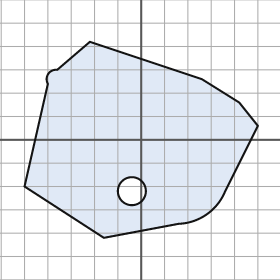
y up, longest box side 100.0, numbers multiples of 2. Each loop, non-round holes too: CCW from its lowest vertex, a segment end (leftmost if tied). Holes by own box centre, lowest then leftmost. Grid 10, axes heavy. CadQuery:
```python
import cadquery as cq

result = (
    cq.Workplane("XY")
    .moveTo(-16.0, -42.0)
    .lineTo(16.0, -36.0)
    .threePointArc((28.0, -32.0), (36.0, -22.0))
    .lineTo(50.0, 6.0)
    .lineTo(42.0, 16.0)
    .lineTo(26.0, 26.0)
    .lineTo(-22.0, 42.0)
    .lineTo(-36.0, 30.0)
    .threePointArc((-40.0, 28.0), (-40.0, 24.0))
    .lineTo(-50.0, -20.0)
    .close()
    .moveTo(-4.0, -22.0)
    .circle(6.0)
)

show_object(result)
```